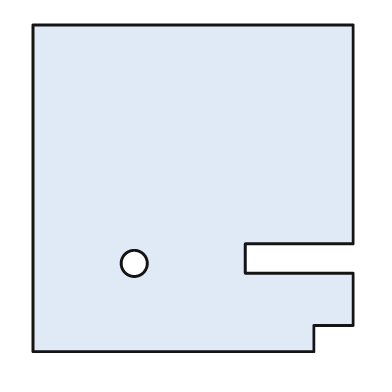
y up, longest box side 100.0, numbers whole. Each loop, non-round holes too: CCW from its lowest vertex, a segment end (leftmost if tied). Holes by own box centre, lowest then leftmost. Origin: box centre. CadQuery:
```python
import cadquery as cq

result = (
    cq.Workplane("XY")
    .moveTo(-49.0, -50.0)
    .lineTo(37.0, -50.0)
    .lineTo(37.0, -42.0)
    .lineTo(49.0, -42.0)
    .lineTo(49.0, -26.0)
    .lineTo(16.0, -26.0)
    .lineTo(16.0, -17.0)
    .lineTo(49.0, -17.0)
    .lineTo(49.0, 50.0)
    .lineTo(-49.0, 50.0)
    .close()
    .moveTo(-18.0, -23.0)
    .circle(4.0)
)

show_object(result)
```